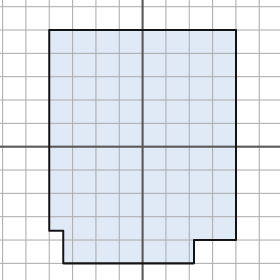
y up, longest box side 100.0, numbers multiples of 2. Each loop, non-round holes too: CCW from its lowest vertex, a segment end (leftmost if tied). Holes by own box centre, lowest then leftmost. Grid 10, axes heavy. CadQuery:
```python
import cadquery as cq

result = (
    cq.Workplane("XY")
    .moveTo(-34.0, -50.0)
    .lineTo(22.0, -50.0)
    .lineTo(22.0, -40.0)
    .lineTo(40.0, -40.0)
    .lineTo(40.0, 50.0)
    .lineTo(-40.0, 50.0)
    .lineTo(-40.0, -36.0)
    .lineTo(-34.0, -36.0)
    .close()
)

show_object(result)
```